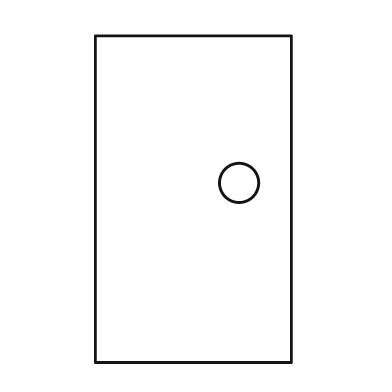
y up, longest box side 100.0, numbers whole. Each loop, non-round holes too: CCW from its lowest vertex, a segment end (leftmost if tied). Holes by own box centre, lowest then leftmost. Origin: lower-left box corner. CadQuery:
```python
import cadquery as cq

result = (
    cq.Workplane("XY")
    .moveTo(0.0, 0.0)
    .lineTo(60.0, 0.0)
    .lineTo(60.0, 100.0)
    .lineTo(0.0, 100.0)
    .close()
    .moveTo(44.0, 55.0)
    .circle(6.0)
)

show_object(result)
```